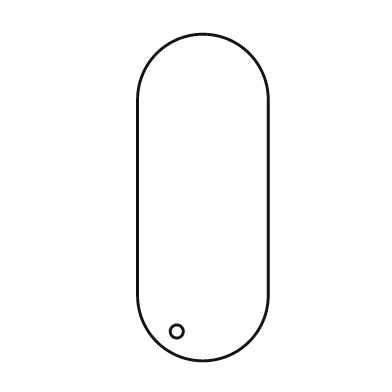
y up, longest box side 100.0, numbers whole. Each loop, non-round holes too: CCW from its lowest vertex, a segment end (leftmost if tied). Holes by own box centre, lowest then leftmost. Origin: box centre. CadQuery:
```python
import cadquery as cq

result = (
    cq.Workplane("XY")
    .moveTo(-20.0, -30.0)
    .threePointArc((0.0, -50.0), (20.0, -30.0))
    .lineTo(20.0, 30.0)
    .threePointArc((0.0, 50.0), (-20.0, 30.0))
    .close()
    .moveTo(-8.0, -41.0)
    .circle(2.0)
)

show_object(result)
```